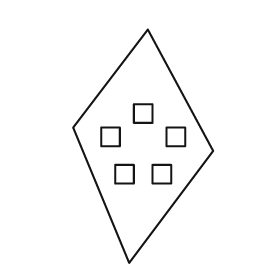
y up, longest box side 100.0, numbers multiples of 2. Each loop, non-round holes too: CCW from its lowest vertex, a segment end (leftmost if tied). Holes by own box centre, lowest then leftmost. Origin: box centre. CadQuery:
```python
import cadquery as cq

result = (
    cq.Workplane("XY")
    .moveTo(-6.0, -50.0)
    .lineTo(30.0, -2.0)
    .lineTo(2.0, 50.0)
    .lineTo(-30.0, 8.0)
    .close()
    .moveTo(-12.0, -16.0)
    .lineTo(-4.0, -16.0)
    .lineTo(-4.0, -8.0)
    .lineTo(-12.0, -8.0)
    .close()
    .moveTo(4.0, -16.0)
    .lineTo(12.0, -16.0)
    .lineTo(12.0, -8.0)
    .lineTo(4.0, -8.0)
    .close()
    .moveTo(-18.0, 0.0)
    .lineTo(-10.0, 0.0)
    .lineTo(-10.0, 8.0)
    .lineTo(-18.0, 8.0)
    .close()
    .moveTo(10.0, 0.0)
    .lineTo(18.0, 0.0)
    .lineTo(18.0, 8.0)
    .lineTo(10.0, 8.0)
    .close()
    .moveTo(-4.0, 10.0)
    .lineTo(4.0, 10.0)
    .lineTo(4.0, 18.0)
    .lineTo(-4.0, 18.0)
    .close()
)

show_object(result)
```